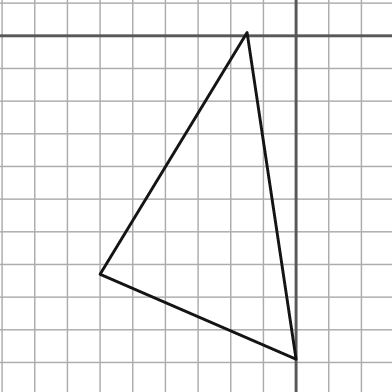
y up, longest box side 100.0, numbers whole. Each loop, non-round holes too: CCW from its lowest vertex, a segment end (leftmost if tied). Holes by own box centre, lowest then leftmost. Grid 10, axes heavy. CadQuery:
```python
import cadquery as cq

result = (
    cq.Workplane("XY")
    .moveTo(0.0, -99.0)
    .lineTo(-15.0, 1.0)
    .lineTo(-60.0, -73.0)
    .close()
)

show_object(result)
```